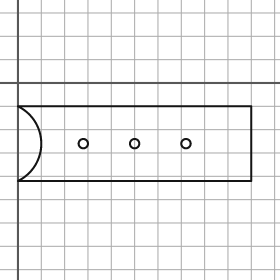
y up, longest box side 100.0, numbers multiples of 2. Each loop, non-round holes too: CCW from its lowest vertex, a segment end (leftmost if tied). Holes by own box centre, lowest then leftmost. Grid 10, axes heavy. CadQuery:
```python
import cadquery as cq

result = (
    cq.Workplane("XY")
    .moveTo(0.0, -42.0)
    .lineTo(100.0, -42.0)
    .lineTo(100.0, -10.0)
    .lineTo(0.0, -10.0)
    .threePointArc((10.0, -26.0), (0.0, -42.0))
    .close()
    .moveTo(28.0, -26.0)
    .circle(2.0)
    .moveTo(50.0, -26.0)
    .circle(2.0)
    .moveTo(72.0, -26.0)
    .circle(2.0)
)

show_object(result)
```